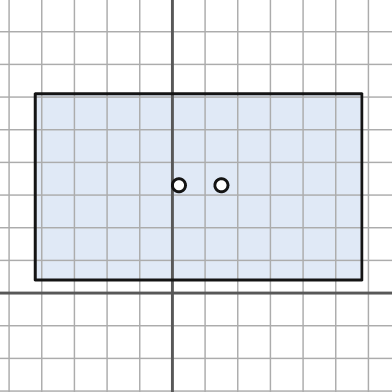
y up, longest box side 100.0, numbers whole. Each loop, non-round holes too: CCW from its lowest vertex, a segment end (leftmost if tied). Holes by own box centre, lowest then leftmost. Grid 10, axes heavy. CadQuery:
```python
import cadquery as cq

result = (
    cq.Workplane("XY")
    .moveTo(-42.0, 4.0)
    .lineTo(58.0, 4.0)
    .lineTo(58.0, 61.0)
    .lineTo(-42.0, 61.0)
    .close()
    .moveTo(2.0, 33.0)
    .circle(2.0)
    .moveTo(15.0, 33.0)
    .circle(2.0)
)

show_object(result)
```